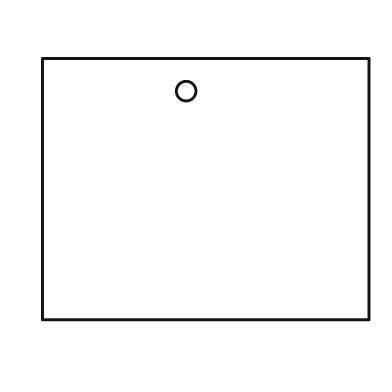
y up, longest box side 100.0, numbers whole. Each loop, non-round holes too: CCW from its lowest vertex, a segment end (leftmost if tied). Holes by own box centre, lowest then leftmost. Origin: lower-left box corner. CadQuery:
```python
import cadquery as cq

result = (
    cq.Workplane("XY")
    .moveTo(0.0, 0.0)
    .lineTo(100.0, 0.0)
    .lineTo(100.0, 80.0)
    .lineTo(0.0, 80.0)
    .close()
    .moveTo(44.0, 70.0)
    .circle(3.0)
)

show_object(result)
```